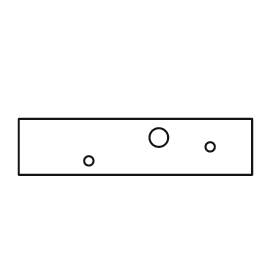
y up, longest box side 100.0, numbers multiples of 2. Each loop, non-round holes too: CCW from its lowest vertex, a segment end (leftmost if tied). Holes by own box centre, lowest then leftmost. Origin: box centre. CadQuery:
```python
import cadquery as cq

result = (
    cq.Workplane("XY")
    .moveTo(-50.0, -12.0)
    .lineTo(50.0, -12.0)
    .lineTo(50.0, 12.0)
    .lineTo(-50.0, 12.0)
    .close()
    .moveTo(-20.0, -6.0)
    .circle(2.0)
    .moveTo(32.0, 0.0)
    .circle(2.0)
    .moveTo(10.0, 4.0)
    .circle(4.0)
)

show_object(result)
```